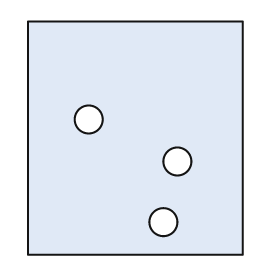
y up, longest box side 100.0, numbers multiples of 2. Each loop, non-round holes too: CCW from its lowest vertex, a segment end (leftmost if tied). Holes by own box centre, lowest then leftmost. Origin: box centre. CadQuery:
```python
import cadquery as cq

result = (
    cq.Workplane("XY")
    .moveTo(-46.0, -50.0)
    .lineTo(46.0, -50.0)
    .lineTo(46.0, 50.0)
    .lineTo(-46.0, 50.0)
    .close()
    .moveTo(12.0, -36.0)
    .circle(6.0)
    .moveTo(18.0, -10.0)
    .circle(6.0)
    .moveTo(-20.0, 8.0)
    .circle(6.0)
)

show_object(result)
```